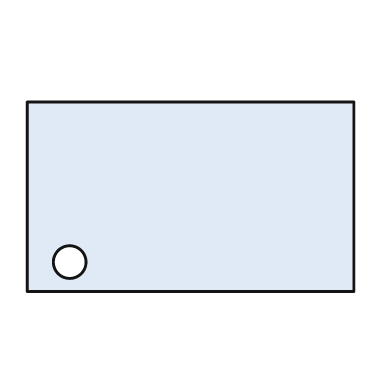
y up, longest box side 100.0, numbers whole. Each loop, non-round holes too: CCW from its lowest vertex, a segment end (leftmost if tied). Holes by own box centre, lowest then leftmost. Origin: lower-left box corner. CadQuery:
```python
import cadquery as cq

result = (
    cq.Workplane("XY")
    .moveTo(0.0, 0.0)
    .lineTo(100.0, 0.0)
    .lineTo(100.0, 58.0)
    .lineTo(0.0, 58.0)
    .close()
    .moveTo(13.0, 9.0)
    .circle(5.0)
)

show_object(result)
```